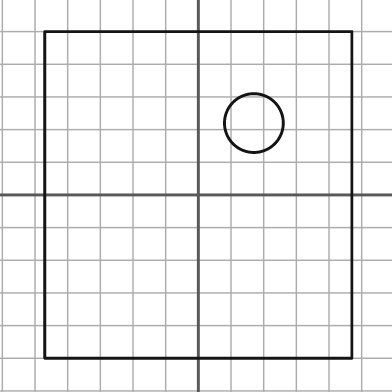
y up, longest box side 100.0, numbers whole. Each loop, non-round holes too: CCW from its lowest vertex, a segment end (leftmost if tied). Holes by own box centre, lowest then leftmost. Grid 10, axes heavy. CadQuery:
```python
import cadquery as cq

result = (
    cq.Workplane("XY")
    .moveTo(-47.0, -50.0)
    .lineTo(47.0, -50.0)
    .lineTo(47.0, 50.0)
    .lineTo(-47.0, 50.0)
    .close()
    .moveTo(17.0, 22.0)
    .circle(9.0)
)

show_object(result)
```